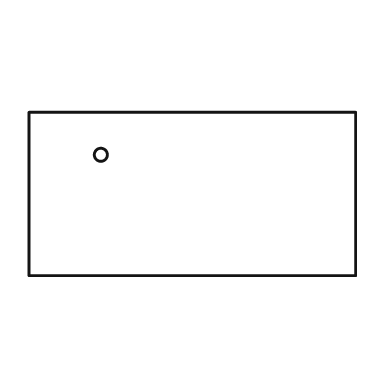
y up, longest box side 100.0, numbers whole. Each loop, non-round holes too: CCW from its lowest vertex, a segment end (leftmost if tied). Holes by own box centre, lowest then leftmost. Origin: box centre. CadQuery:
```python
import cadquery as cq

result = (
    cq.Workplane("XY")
    .moveTo(-50.0, -25.0)
    .lineTo(50.0, -25.0)
    .lineTo(50.0, 25.0)
    .lineTo(-50.0, 25.0)
    .close()
    .moveTo(-28.0, 12.0)
    .circle(2.0)
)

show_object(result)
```